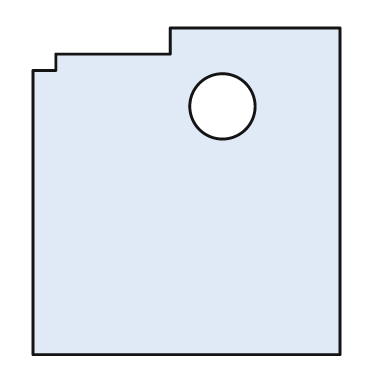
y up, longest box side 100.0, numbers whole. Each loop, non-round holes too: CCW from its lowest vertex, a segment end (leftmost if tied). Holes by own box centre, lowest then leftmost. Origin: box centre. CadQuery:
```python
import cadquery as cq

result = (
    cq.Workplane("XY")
    .moveTo(-47.0, -50.0)
    .lineTo(47.0, -50.0)
    .lineTo(47.0, 50.0)
    .lineTo(-5.0, 50.0)
    .lineTo(-5.0, 42.0)
    .lineTo(-40.0, 42.0)
    .lineTo(-40.0, 37.0)
    .lineTo(-47.0, 37.0)
    .close()
    .moveTo(11.0, 26.0)
    .circle(10.0)
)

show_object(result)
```